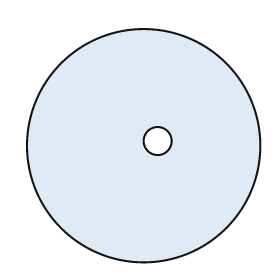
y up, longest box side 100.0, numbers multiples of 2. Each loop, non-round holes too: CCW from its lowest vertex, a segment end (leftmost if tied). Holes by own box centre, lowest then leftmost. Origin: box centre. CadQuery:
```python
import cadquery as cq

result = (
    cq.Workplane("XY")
    .moveTo(0.0, 0.0)
    .circle(50.0)
    .moveTo(6.0, 2.0)
    .circle(6.0)
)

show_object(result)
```